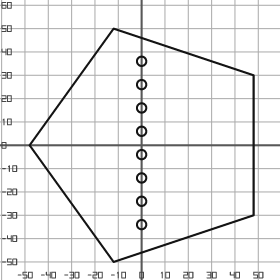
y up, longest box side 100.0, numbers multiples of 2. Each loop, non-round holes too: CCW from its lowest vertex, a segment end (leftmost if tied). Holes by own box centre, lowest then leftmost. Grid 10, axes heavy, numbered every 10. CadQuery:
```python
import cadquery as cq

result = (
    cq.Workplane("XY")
    .moveTo(-12.0, -50.0)
    .lineTo(48.0, -30.0)
    .lineTo(48.0, 30.0)
    .lineTo(-12.0, 50.0)
    .lineTo(-48.0, 0.0)
    .close()
    .moveTo(0.0, -34.0)
    .circle(2.0)
    .moveTo(0.0, -24.0)
    .circle(2.0)
    .moveTo(0.0, -14.0)
    .circle(2.0)
    .moveTo(0.0, -4.0)
    .circle(2.0)
    .moveTo(0.0, 6.0)
    .circle(2.0)
    .moveTo(0.0, 16.0)
    .circle(2.0)
    .moveTo(0.0, 26.0)
    .circle(2.0)
    .moveTo(0.0, 36.0)
    .circle(2.0)
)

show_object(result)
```